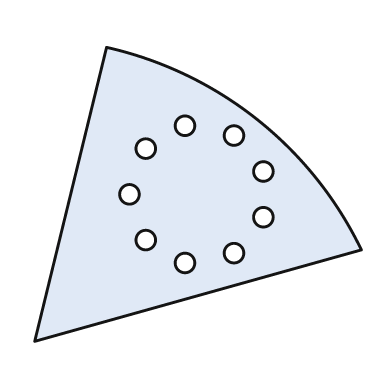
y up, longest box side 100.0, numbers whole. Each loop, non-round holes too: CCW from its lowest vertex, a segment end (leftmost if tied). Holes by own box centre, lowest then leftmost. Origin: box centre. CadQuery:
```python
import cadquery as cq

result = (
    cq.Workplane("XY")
    .moveTo(-50.0, -45.0)
    .lineTo(50.0, -17.0)
    .threePointArc((18.0, 23.0), (-28.0, 45.0))
    .close()
    .moveTo(-4.0, -21.0)
    .circle(3.0)
    .moveTo(11.0, -18.0)
    .circle(3.0)
    .moveTo(-16.0, -14.0)
    .circle(3.0)
    .moveTo(20.0, -7.0)
    .circle(3.0)
    .moveTo(-21.0, 0.0)
    .circle(3.0)
    .moveTo(20.0, 7.0)
    .circle(3.0)
    .moveTo(-16.0, 14.0)
    .circle(3.0)
    .moveTo(11.0, 18.0)
    .circle(3.0)
    .moveTo(-4.0, 21.0)
    .circle(3.0)
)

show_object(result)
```